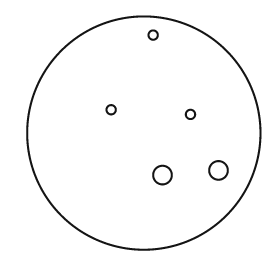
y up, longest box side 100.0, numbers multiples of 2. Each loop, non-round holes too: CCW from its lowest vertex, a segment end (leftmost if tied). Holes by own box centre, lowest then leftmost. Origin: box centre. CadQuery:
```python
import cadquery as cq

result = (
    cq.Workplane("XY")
    .moveTo(0.0, 0.0)
    .circle(50.0)
    .moveTo(8.0, -18.0)
    .circle(4.0)
    .moveTo(32.0, -16.0)
    .circle(4.0)
    .moveTo(20.0, 8.0)
    .circle(2.0)
    .moveTo(-14.0, 10.0)
    .circle(2.0)
    .moveTo(4.0, 42.0)
    .circle(2.0)
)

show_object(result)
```